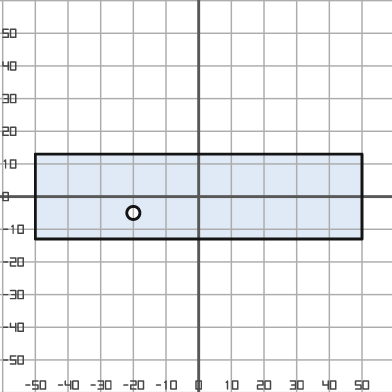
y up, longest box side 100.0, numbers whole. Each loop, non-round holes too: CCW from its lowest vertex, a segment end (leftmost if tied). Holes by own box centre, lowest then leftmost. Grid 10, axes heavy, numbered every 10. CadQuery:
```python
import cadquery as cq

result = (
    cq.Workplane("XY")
    .moveTo(-50.0, -13.0)
    .lineTo(50.0, -13.0)
    .lineTo(50.0, 13.0)
    .lineTo(-50.0, 13.0)
    .close()
    .moveTo(-20.0, -5.0)
    .circle(2.0)
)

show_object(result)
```